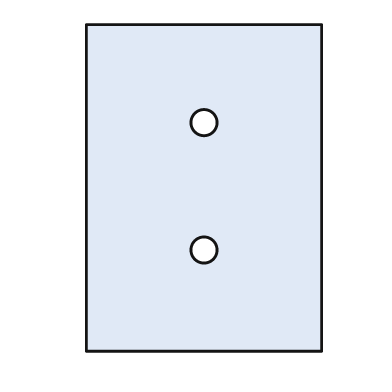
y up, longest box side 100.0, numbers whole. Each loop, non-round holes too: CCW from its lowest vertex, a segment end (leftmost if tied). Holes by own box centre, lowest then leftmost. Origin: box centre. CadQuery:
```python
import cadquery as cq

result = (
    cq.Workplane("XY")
    .moveTo(-36.0, -50.0)
    .lineTo(36.0, -50.0)
    .lineTo(36.0, 50.0)
    .lineTo(-36.0, 50.0)
    .close()
    .moveTo(0.0, -19.0)
    .circle(4.0)
    .moveTo(0.0, 20.0)
    .circle(4.0)
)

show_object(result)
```